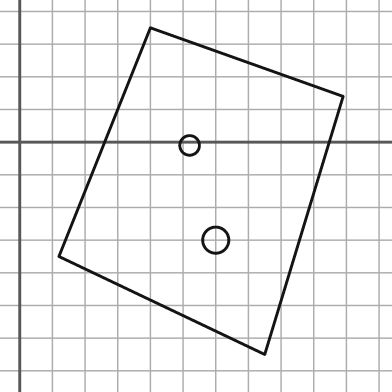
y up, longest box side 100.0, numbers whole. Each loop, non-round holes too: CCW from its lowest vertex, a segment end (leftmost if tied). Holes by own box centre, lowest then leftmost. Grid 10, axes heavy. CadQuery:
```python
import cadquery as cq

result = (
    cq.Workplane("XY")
    .moveTo(75.0, -65.0)
    .lineTo(99.0, 14.0)
    .lineTo(40.0, 35.0)
    .lineTo(12.0, -35.0)
    .close()
    .moveTo(60.0, -30.0)
    .circle(4.0)
    .moveTo(52.0, -1.0)
    .circle(3.0)
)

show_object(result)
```